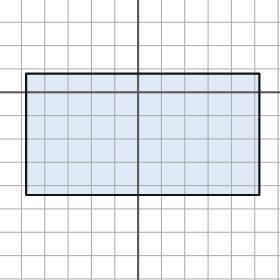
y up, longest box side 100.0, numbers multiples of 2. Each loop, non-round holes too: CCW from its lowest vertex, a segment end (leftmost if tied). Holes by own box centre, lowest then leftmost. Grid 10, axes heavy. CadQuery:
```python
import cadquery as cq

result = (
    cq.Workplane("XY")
    .moveTo(-48.0, -44.0)
    .lineTo(52.0, -44.0)
    .lineTo(52.0, 8.0)
    .lineTo(-48.0, 8.0)
    .close()
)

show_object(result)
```